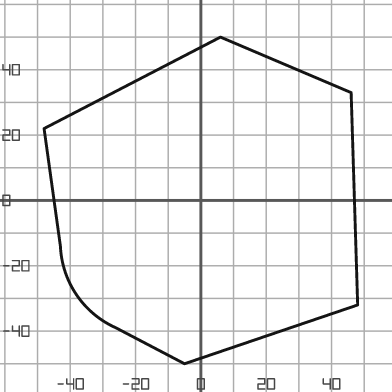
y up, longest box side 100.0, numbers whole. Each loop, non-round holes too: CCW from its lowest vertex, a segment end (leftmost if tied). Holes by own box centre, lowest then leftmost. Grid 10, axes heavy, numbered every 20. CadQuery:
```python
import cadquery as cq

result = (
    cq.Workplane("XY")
    .moveTo(-5.0, -50.0)
    .lineTo(48.0, -32.0)
    .lineTo(46.0, 33.0)
    .lineTo(6.0, 50.0)
    .lineTo(-48.0, 22.0)
    .lineTo(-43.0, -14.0)
    .threePointArc((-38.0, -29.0), (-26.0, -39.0))
    .close()
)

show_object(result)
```